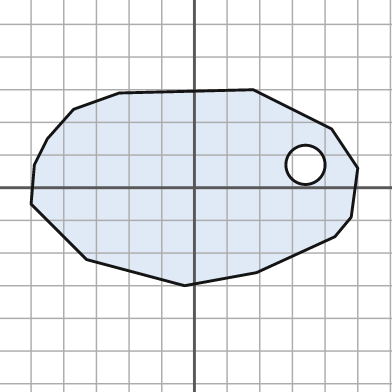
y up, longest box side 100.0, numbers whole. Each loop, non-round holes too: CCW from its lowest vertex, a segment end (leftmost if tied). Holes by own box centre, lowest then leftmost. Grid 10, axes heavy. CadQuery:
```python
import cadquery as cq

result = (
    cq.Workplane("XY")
    .moveTo(-3.0, -30.0)
    .lineTo(19.0, -26.0)
    .lineTo(43.0, -15.0)
    .lineTo(48.0, -9.0)
    .lineTo(50.0, 6.0)
    .lineTo(42.0, 18.0)
    .lineTo(18.0, 30.0)
    .lineTo(-23.0, 29.0)
    .lineTo(-37.0, 24.0)
    .lineTo(-45.0, 15.0)
    .lineTo(-49.0, 7.0)
    .lineTo(-50.0, -5.0)
    .lineTo(-33.0, -22.0)
    .close()
    .moveTo(34.0, 7.0)
    .circle(6.0)
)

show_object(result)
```